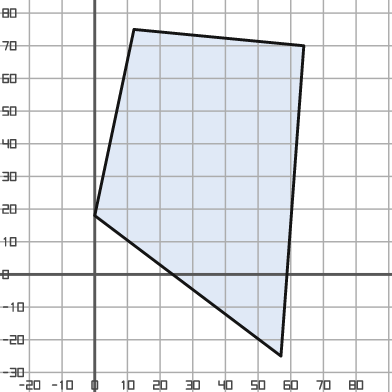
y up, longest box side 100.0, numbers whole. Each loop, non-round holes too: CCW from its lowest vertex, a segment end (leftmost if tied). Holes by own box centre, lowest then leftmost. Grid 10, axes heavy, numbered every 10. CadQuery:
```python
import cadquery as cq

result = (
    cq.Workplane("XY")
    .moveTo(57.0, -25.0)
    .lineTo(64.0, 70.0)
    .lineTo(12.0, 75.0)
    .lineTo(0.0, 18.0)
    .close()
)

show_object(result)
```